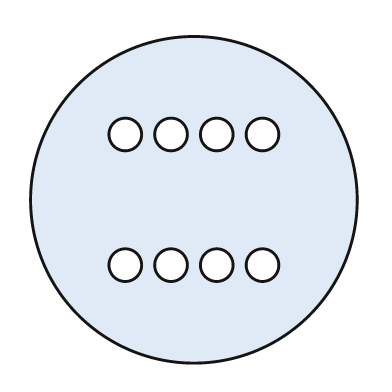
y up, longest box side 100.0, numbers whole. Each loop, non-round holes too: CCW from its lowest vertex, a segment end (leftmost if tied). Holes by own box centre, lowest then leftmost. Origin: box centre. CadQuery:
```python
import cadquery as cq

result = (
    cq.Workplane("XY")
    .moveTo(0.0, 0.0)
    .circle(50.0)
    .moveTo(-21.0, -20.0)
    .circle(5.0)
    .moveTo(-7.0, -20.0)
    .circle(5.0)
    .moveTo(7.0, -20.0)
    .circle(5.0)
    .moveTo(21.0, -20.0)
    .circle(5.0)
    .moveTo(-21.0, 20.0)
    .circle(5.0)
    .moveTo(-7.0, 20.0)
    .circle(5.0)
    .moveTo(7.0, 20.0)
    .circle(5.0)
    .moveTo(21.0, 20.0)
    .circle(5.0)
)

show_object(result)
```